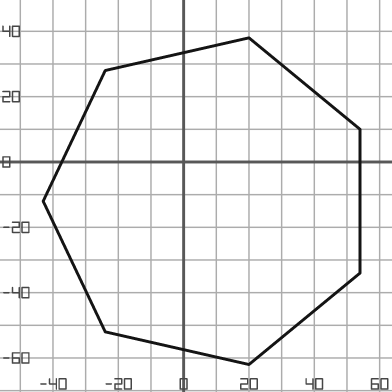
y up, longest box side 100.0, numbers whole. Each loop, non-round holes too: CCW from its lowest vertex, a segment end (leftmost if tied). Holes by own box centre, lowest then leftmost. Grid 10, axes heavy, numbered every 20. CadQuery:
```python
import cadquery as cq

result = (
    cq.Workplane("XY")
    .moveTo(20.0, -62.0)
    .lineTo(54.0, -34.0)
    .lineTo(54.0, 10.0)
    .lineTo(20.0, 38.0)
    .lineTo(-24.0, 28.0)
    .lineTo(-43.0, -12.0)
    .lineTo(-24.0, -52.0)
    .close()
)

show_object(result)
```